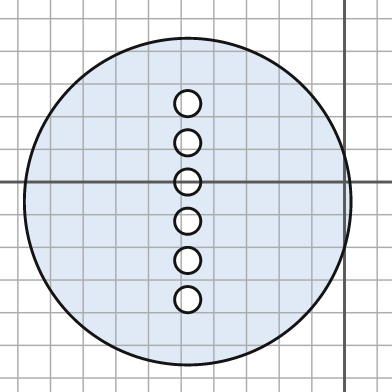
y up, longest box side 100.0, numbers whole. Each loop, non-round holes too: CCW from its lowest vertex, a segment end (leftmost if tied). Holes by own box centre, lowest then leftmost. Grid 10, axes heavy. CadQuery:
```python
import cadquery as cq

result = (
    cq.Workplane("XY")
    .moveTo(-48.0, -6.0)
    .circle(50.0)
    .moveTo(-48.0, -36.0)
    .circle(4.0)
    .moveTo(-48.0, -24.0)
    .circle(4.0)
    .moveTo(-48.0, -12.0)
    .circle(4.0)
    .moveTo(-48.0, 0.0)
    .circle(4.0)
    .moveTo(-48.0, 12.0)
    .circle(4.0)
    .moveTo(-48.0, 24.0)
    .circle(4.0)
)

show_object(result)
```